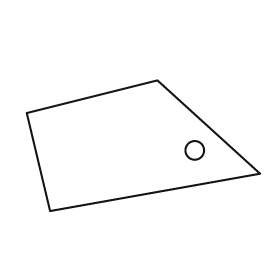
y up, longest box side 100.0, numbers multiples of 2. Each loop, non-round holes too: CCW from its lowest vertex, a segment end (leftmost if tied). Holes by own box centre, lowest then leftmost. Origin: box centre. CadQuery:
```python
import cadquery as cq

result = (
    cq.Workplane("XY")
    .moveTo(-40.0, -28.0)
    .lineTo(50.0, -12.0)
    .lineTo(6.0, 28.0)
    .lineTo(-50.0, 14.0)
    .close()
    .moveTo(22.0, -2.0)
    .circle(4.0)
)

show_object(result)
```